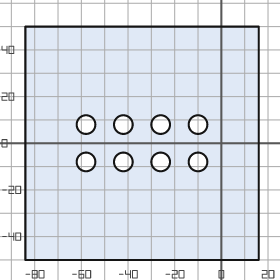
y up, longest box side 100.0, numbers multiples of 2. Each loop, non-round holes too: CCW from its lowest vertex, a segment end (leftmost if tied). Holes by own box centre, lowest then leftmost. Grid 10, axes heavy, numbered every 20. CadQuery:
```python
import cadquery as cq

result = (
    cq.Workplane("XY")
    .moveTo(-84.0, -50.0)
    .lineTo(16.0, -50.0)
    .lineTo(16.0, 50.0)
    .lineTo(-84.0, 50.0)
    .close()
    .moveTo(-58.0, -8.0)
    .circle(4.0)
    .moveTo(-42.0, -8.0)
    .circle(4.0)
    .moveTo(-26.0, -8.0)
    .circle(4.0)
    .moveTo(-10.0, -8.0)
    .circle(4.0)
    .moveTo(-58.0, 8.0)
    .circle(4.0)
    .moveTo(-42.0, 8.0)
    .circle(4.0)
    .moveTo(-26.0, 8.0)
    .circle(4.0)
    .moveTo(-10.0, 8.0)
    .circle(4.0)
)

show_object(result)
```